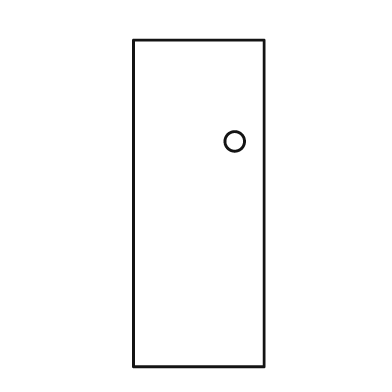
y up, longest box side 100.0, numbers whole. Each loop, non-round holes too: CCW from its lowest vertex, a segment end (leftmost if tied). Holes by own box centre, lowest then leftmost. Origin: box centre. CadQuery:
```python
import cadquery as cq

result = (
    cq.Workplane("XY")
    .moveTo(-20.0, -50.0)
    .lineTo(20.0, -50.0)
    .lineTo(20.0, 50.0)
    .lineTo(-20.0, 50.0)
    .close()
    .moveTo(11.0, 19.0)
    .circle(3.0)
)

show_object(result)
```